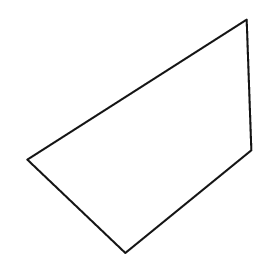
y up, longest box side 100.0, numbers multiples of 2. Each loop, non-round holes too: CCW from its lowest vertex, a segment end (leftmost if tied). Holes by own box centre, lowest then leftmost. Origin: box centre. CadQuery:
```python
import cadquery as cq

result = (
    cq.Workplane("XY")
    .moveTo(-6.0, -50.0)
    .lineTo(48.0, -6.0)
    .lineTo(46.0, 50.0)
    .lineTo(-48.0, -10.0)
    .close()
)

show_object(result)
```